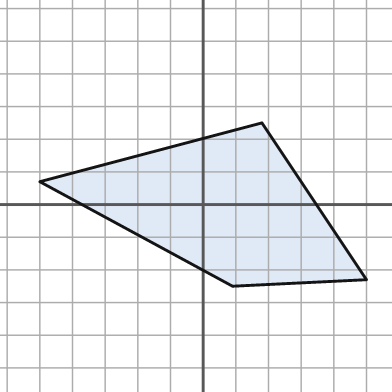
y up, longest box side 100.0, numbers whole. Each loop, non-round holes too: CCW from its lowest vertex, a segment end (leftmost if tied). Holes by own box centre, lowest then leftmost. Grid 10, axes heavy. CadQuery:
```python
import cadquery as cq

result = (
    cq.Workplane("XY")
    .moveTo(9.0, -25.0)
    .lineTo(50.0, -23.0)
    .lineTo(18.0, 25.0)
    .lineTo(-50.0, 7.0)
    .close()
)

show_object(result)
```